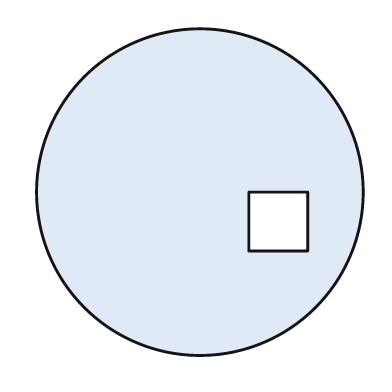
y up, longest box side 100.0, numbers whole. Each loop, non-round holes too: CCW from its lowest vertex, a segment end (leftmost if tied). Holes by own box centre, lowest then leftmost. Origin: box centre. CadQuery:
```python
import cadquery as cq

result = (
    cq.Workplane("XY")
    .moveTo(0.0, 0.0)
    .circle(50.0)
    .moveTo(15.0, -18.0)
    .lineTo(33.0, -18.0)
    .lineTo(33.0, 0.0)
    .lineTo(15.0, 0.0)
    .close()
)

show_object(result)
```